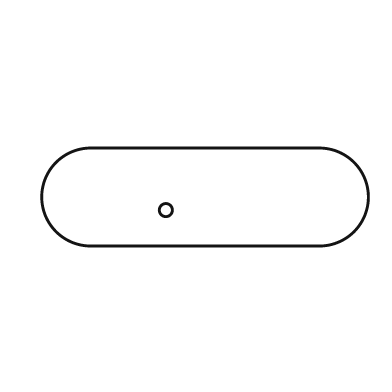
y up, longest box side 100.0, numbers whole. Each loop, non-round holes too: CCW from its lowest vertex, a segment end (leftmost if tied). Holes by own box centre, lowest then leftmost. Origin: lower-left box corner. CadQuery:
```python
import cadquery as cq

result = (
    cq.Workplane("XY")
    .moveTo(15.0, 0.0)
    .lineTo(85.0, 0.0)
    .threePointArc((100.0, 15.0), (85.0, 30.0))
    .lineTo(15.0, 30.0)
    .threePointArc((0.0, 15.0), (15.0, 0.0))
    .close()
    .moveTo(38.0, 11.0)
    .circle(2.0)
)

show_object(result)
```